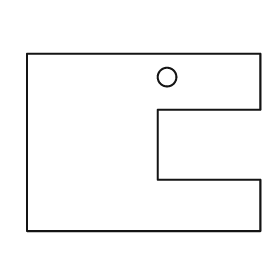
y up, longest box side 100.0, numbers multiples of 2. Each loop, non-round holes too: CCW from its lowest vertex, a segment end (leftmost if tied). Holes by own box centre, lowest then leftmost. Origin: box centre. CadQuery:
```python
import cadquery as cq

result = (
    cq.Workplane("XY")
    .moveTo(-50.0, -38.0)
    .lineTo(50.0, -38.0)
    .lineTo(50.0, -16.0)
    .lineTo(6.0, -16.0)
    .lineTo(6.0, 14.0)
    .lineTo(50.0, 14.0)
    .lineTo(50.0, 38.0)
    .lineTo(-50.0, 38.0)
    .close()
    .moveTo(10.0, 28.0)
    .circle(4.0)
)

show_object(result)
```